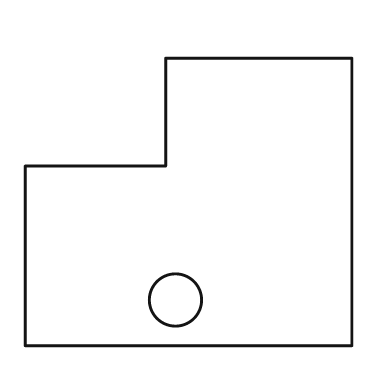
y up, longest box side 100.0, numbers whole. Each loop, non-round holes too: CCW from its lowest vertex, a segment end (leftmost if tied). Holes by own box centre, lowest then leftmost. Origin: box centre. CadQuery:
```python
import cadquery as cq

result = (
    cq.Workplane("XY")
    .moveTo(-50.0, -44.0)
    .lineTo(50.0, -44.0)
    .lineTo(50.0, 44.0)
    .lineTo(-7.0, 44.0)
    .lineTo(-7.0, 11.0)
    .lineTo(-50.0, 11.0)
    .close()
    .moveTo(-4.0, -30.0)
    .circle(8.0)
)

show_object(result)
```